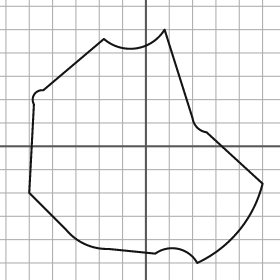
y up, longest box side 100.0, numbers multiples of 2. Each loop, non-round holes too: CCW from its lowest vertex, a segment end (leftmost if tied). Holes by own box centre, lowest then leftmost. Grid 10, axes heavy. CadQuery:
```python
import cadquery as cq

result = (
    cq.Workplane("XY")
    .moveTo(22.0, -50.0)
    .threePointArc((40.0, -36.0), (50.0, -16.0))
    .lineTo(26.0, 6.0)
    .threePointArc((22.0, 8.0), (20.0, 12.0))
    .lineTo(8.0, 50.0)
    .threePointArc((-4.0, 42.0), (-18.0, 46.0))
    .lineTo(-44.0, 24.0)
    .threePointArc((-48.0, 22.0), (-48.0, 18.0))
    .lineTo(-50.0, -20.0)
    .lineTo(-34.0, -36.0)
    .threePointArc((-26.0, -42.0), (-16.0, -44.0))
    .lineTo(4.0, -46.0)
    .threePointArc((14.0, -44.0), (22.0, -50.0))
    .close()
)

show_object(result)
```